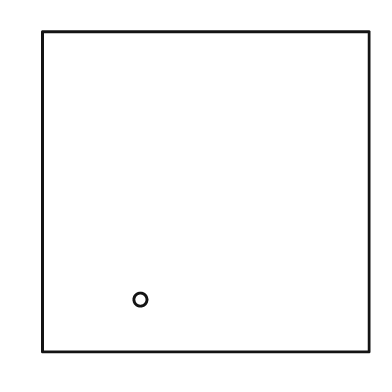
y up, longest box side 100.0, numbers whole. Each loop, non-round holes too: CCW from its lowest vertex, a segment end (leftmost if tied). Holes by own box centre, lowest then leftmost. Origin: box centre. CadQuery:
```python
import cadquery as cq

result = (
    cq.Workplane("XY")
    .moveTo(-50.0, -49.0)
    .lineTo(50.0, -49.0)
    .lineTo(50.0, 49.0)
    .lineTo(-50.0, 49.0)
    .close()
    .moveTo(-20.0, -33.0)
    .circle(2.0)
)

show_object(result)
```